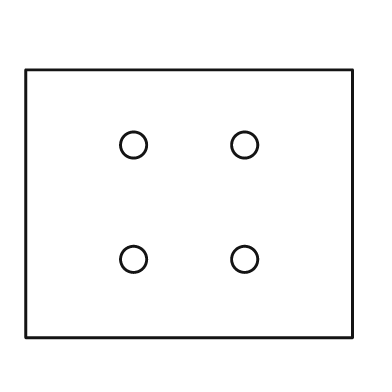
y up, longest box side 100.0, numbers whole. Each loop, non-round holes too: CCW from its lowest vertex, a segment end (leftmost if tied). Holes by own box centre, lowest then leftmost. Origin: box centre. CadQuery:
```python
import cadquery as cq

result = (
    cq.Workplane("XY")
    .moveTo(-50.0, -41.0)
    .lineTo(50.0, -41.0)
    .lineTo(50.0, 41.0)
    .lineTo(-50.0, 41.0)
    .close()
    .moveTo(-17.0, -17.0)
    .circle(4.0)
    .moveTo(17.0, -17.0)
    .circle(4.0)
    .moveTo(-17.0, 18.0)
    .circle(4.0)
    .moveTo(17.0, 18.0)
    .circle(4.0)
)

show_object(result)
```